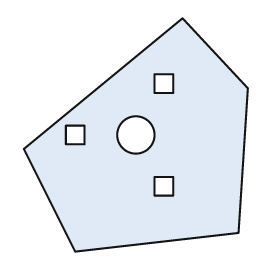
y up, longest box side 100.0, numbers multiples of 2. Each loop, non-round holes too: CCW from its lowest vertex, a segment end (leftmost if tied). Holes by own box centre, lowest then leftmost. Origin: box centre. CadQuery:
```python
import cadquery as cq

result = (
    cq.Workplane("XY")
    .moveTo(-26.0, -50.0)
    .lineTo(44.0, -42.0)
    .lineTo(48.0, 20.0)
    .lineTo(20.0, 50.0)
    .lineTo(-48.0, -6.0)
    .close()
    .moveTo(8.0, -26.0)
    .lineTo(16.0, -26.0)
    .lineTo(16.0, -18.0)
    .lineTo(8.0, -18.0)
    .close()
    .moveTo(-30.0, -4.0)
    .lineTo(-22.0, -4.0)
    .lineTo(-22.0, 4.0)
    .lineTo(-30.0, 4.0)
    .close()
    .moveTo(0.0, 0.0)
    .circle(8.0)
    .moveTo(8.0, 18.0)
    .lineTo(16.0, 18.0)
    .lineTo(16.0, 26.0)
    .lineTo(8.0, 26.0)
    .close()
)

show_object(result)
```